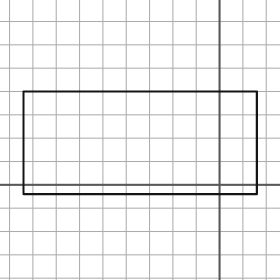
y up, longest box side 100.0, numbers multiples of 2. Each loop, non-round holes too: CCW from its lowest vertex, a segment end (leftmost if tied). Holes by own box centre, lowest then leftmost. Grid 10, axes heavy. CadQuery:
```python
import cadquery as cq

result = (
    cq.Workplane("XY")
    .moveTo(-84.0, -4.0)
    .lineTo(16.0, -4.0)
    .lineTo(16.0, 40.0)
    .lineTo(-84.0, 40.0)
    .close()
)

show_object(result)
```